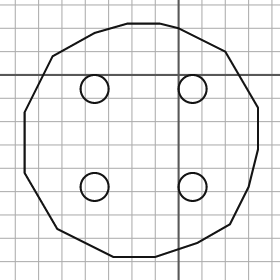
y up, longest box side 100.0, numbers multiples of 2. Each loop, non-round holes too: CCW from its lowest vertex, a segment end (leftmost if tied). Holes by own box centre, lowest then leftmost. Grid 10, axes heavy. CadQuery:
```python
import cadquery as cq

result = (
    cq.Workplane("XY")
    .moveTo(-28.0, -78.0)
    .lineTo(-10.0, -78.0)
    .lineTo(8.0, -72.0)
    .lineTo(22.0, -64.0)
    .lineTo(30.0, -48.0)
    .lineTo(34.0, -32.0)
    .lineTo(34.0, -14.0)
    .lineTo(20.0, 10.0)
    .lineTo(0.0, 20.0)
    .lineTo(-8.0, 22.0)
    .lineTo(-22.0, 22.0)
    .lineTo(-36.0, 18.0)
    .lineTo(-54.0, 8.0)
    .lineTo(-66.0, -16.0)
    .lineTo(-66.0, -42.0)
    .lineTo(-52.0, -66.0)
    .close()
    .moveTo(-36.0, -48.0)
    .circle(6.0)
    .moveTo(6.0, -48.0)
    .circle(6.0)
    .moveTo(-36.0, -6.0)
    .circle(6.0)
    .moveTo(6.0, -6.0)
    .circle(6.0)
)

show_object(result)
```